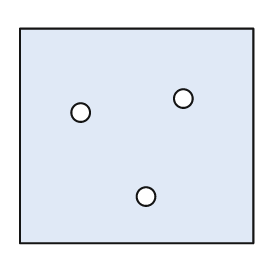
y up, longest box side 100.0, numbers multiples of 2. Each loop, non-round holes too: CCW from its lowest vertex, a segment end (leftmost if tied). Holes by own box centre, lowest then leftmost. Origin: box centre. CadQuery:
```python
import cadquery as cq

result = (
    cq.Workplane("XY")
    .moveTo(-50.0, -46.0)
    .lineTo(50.0, -46.0)
    .lineTo(50.0, 46.0)
    .lineTo(-50.0, 46.0)
    .close()
    .moveTo(4.0, -26.0)
    .circle(4.0)
    .moveTo(-24.0, 10.0)
    .circle(4.0)
    .moveTo(20.0, 16.0)
    .circle(4.0)
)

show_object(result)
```